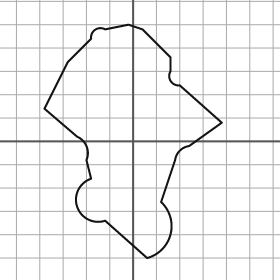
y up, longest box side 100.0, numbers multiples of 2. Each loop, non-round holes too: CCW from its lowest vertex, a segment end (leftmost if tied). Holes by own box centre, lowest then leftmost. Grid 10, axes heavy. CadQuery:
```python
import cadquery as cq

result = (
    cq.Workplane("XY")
    .moveTo(6.0, -50.0)
    .threePointArc((16.0, -40.0), (12.0, -26.0))
    .lineTo(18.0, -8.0)
    .threePointArc((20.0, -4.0), (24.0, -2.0))
    .lineTo(38.0, 8.0)
    .lineTo(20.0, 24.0)
    .threePointArc((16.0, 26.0), (16.0, 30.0))
    .lineTo(16.0, 36.0)
    .lineTo(4.0, 48.0)
    .lineTo(-2.0, 50.0)
    .lineTo(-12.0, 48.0)
    .threePointArc((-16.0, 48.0), (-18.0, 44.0))
    .lineTo(-28.0, 34.0)
    .lineTo(-38.0, 14.0)
    .lineTo(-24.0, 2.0)
    .threePointArc((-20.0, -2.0), (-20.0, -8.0))
    .lineTo(-18.0, -16.0)
    .threePointArc((-24.0, -28.0), (-12.0, -34.0))
    .close()
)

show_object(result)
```